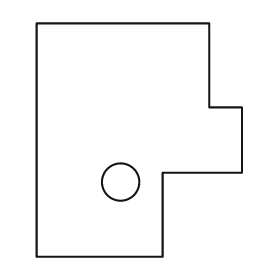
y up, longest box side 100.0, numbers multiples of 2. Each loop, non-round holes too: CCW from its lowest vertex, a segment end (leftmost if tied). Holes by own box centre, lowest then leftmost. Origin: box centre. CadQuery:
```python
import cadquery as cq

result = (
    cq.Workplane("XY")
    .moveTo(-44.0, -50.0)
    .lineTo(10.0, -50.0)
    .lineTo(10.0, -14.0)
    .lineTo(44.0, -14.0)
    .lineTo(44.0, 14.0)
    .lineTo(30.0, 14.0)
    .lineTo(30.0, 50.0)
    .lineTo(-44.0, 50.0)
    .close()
    .moveTo(-8.0, -18.0)
    .circle(8.0)
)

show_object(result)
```